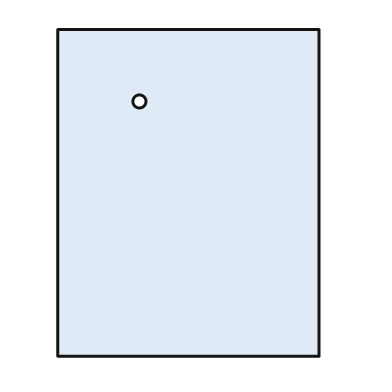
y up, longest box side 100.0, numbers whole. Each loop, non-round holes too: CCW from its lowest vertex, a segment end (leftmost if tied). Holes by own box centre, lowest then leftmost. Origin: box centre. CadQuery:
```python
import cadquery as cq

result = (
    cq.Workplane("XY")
    .moveTo(-40.0, -50.0)
    .lineTo(40.0, -50.0)
    .lineTo(40.0, 50.0)
    .lineTo(-40.0, 50.0)
    .close()
    .moveTo(-15.0, 28.0)
    .circle(2.0)
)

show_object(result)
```